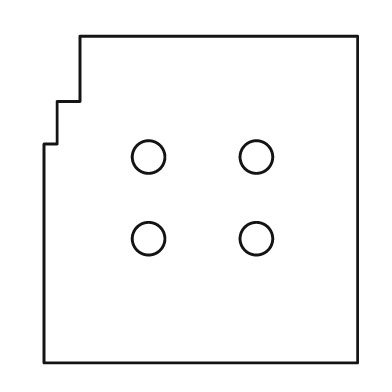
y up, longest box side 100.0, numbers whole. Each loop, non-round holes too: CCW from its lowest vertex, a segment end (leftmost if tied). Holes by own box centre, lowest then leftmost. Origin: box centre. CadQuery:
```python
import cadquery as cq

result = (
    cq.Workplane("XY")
    .moveTo(-48.0, -50.0)
    .lineTo(48.0, -50.0)
    .lineTo(48.0, 50.0)
    .lineTo(-37.0, 50.0)
    .lineTo(-37.0, 30.0)
    .lineTo(-44.0, 30.0)
    .lineTo(-44.0, 17.0)
    .lineTo(-48.0, 17.0)
    .close()
    .moveTo(-16.0, -12.0)
    .circle(5.0)
    .moveTo(17.0, -12.0)
    .circle(5.0)
    .moveTo(-16.0, 13.0)
    .circle(5.0)
    .moveTo(17.0, 13.0)
    .circle(5.0)
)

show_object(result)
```